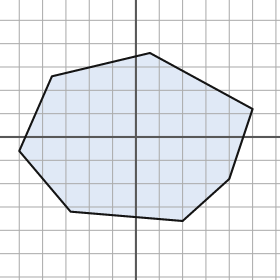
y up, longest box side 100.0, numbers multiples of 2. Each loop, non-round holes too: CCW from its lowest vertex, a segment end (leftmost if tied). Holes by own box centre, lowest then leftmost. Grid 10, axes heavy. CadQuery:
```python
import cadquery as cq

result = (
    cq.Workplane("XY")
    .moveTo(20.0, -36.0)
    .lineTo(40.0, -18.0)
    .lineTo(50.0, 12.0)
    .lineTo(6.0, 36.0)
    .lineTo(-36.0, 26.0)
    .lineTo(-50.0, -6.0)
    .lineTo(-28.0, -32.0)
    .close()
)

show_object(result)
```